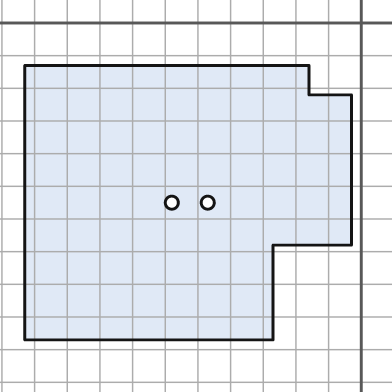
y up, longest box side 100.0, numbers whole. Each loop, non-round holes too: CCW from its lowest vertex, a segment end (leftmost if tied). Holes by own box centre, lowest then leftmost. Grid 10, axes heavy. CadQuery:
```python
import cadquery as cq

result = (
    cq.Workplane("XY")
    .moveTo(-103.0, -97.0)
    .lineTo(-27.0, -97.0)
    .lineTo(-27.0, -68.0)
    .lineTo(-3.0, -68.0)
    .lineTo(-3.0, -22.0)
    .lineTo(-16.0, -22.0)
    .lineTo(-16.0, -13.0)
    .lineTo(-103.0, -13.0)
    .close()
    .moveTo(-58.0, -55.0)
    .circle(2.0)
    .moveTo(-47.0, -55.0)
    .circle(2.0)
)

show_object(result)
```